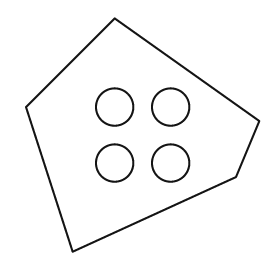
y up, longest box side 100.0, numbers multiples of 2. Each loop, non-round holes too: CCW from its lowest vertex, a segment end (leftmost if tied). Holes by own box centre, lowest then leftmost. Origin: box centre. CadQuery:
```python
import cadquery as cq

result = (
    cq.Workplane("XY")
    .moveTo(-30.0, -50.0)
    .lineTo(40.0, -18.0)
    .lineTo(50.0, 6.0)
    .lineTo(-12.0, 50.0)
    .lineTo(-50.0, 12.0)
    .close()
    .moveTo(-12.0, -12.0)
    .circle(8.0)
    .moveTo(12.0, -12.0)
    .circle(8.0)
    .moveTo(-12.0, 12.0)
    .circle(8.0)
    .moveTo(12.0, 12.0)
    .circle(8.0)
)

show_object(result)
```